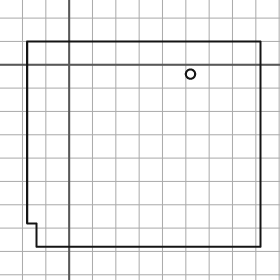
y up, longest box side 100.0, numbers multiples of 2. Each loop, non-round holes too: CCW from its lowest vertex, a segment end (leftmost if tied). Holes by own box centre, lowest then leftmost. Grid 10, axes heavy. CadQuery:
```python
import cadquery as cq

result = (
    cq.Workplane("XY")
    .moveTo(-14.0, -78.0)
    .lineTo(82.0, -78.0)
    .lineTo(82.0, 10.0)
    .lineTo(-18.0, 10.0)
    .lineTo(-18.0, -68.0)
    .lineTo(-14.0, -68.0)
    .close()
    .moveTo(52.0, -4.0)
    .circle(2.0)
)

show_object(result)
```